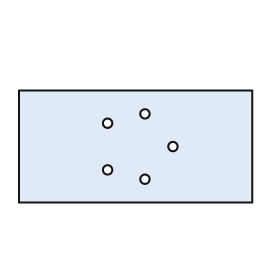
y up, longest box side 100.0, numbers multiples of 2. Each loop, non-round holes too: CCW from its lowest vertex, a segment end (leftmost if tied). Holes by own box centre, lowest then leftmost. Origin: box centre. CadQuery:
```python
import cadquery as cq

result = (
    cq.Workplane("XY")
    .moveTo(-50.0, -24.0)
    .lineTo(50.0, -24.0)
    .lineTo(50.0, 24.0)
    .lineTo(-50.0, 24.0)
    .close()
    .moveTo(4.0, -14.0)
    .circle(2.0)
    .moveTo(-12.0, -10.0)
    .circle(2.0)
    .moveTo(16.0, 0.0)
    .circle(2.0)
    .moveTo(-12.0, 10.0)
    .circle(2.0)
    .moveTo(4.0, 14.0)
    .circle(2.0)
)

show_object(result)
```